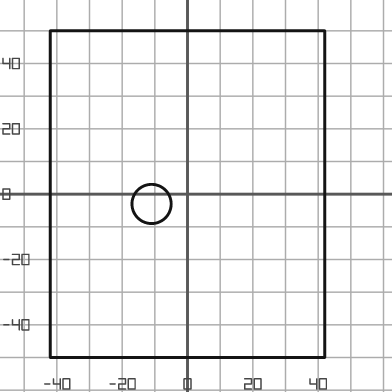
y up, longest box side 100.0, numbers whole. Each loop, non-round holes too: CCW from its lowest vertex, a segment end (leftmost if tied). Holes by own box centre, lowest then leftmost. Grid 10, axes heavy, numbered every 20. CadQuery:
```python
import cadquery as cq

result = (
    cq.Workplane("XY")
    .moveTo(-42.0, -50.0)
    .lineTo(42.0, -50.0)
    .lineTo(42.0, 50.0)
    .lineTo(-42.0, 50.0)
    .close()
    .moveTo(-11.0, -3.0)
    .circle(6.0)
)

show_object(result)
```